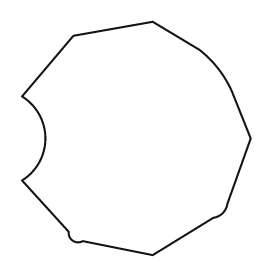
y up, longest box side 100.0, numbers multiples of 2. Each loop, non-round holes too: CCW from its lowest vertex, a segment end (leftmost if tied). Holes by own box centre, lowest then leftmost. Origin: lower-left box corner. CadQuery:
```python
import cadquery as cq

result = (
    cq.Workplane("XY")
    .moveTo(56.0, 0.0)
    .lineTo(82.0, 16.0)
    .threePointArc((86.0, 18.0), (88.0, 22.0))
    .lineTo(98.0, 50.0)
    .lineTo(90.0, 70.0)
    .threePointArc((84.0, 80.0), (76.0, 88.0))
    .lineTo(56.0, 100.0)
    .lineTo(22.0, 94.0)
    .lineTo(0.0, 68.0)
    .threePointArc((10.0, 50.0), (0.0, 32.0))
    .lineTo(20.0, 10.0)
    .threePointArc((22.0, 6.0), (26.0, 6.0))
    .close()
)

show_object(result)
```